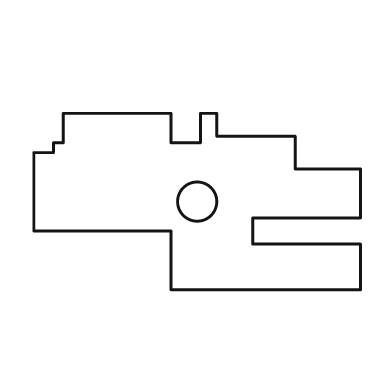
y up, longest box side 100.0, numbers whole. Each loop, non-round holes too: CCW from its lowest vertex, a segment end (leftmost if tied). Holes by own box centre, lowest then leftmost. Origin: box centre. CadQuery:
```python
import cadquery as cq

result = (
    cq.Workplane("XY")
    .moveTo(-8.0, -27.0)
    .lineTo(50.0, -27.0)
    .lineTo(50.0, -13.0)
    .lineTo(17.0, -13.0)
    .lineTo(17.0, -5.0)
    .lineTo(50.0, -5.0)
    .lineTo(50.0, 10.0)
    .lineTo(30.0, 10.0)
    .lineTo(30.0, 20.0)
    .lineTo(6.0, 20.0)
    .lineTo(6.0, 27.0)
    .lineTo(1.0, 27.0)
    .lineTo(1.0, 18.0)
    .lineTo(-8.0, 18.0)
    .lineTo(-8.0, 27.0)
    .lineTo(-41.0, 27.0)
    .lineTo(-41.0, 18.0)
    .lineTo(-44.0, 18.0)
    .lineTo(-44.0, 15.0)
    .lineTo(-50.0, 15.0)
    .lineTo(-50.0, -9.0)
    .lineTo(-8.0, -9.0)
    .close()
    .moveTo(0.0, 0.0)
    .circle(6.0)
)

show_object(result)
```